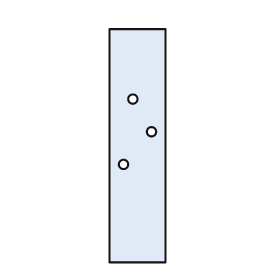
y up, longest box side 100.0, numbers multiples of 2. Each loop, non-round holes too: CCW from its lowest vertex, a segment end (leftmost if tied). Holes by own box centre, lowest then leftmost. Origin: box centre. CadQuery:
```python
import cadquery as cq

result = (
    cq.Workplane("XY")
    .moveTo(-12.0, -50.0)
    .lineTo(12.0, -50.0)
    .lineTo(12.0, 50.0)
    .lineTo(-12.0, 50.0)
    .close()
    .moveTo(-6.0, -8.0)
    .circle(2.0)
    .moveTo(6.0, 6.0)
    .circle(2.0)
    .moveTo(-2.0, 20.0)
    .circle(2.0)
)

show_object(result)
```